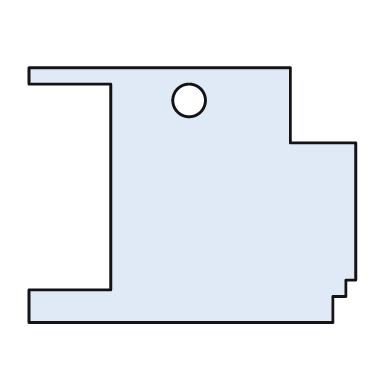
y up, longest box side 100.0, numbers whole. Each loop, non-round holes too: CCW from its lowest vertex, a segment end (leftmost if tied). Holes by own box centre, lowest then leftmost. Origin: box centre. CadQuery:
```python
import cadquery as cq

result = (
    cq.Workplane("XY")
    .moveTo(-50.0, -39.0)
    .lineTo(43.0, -39.0)
    .lineTo(43.0, -31.0)
    .lineTo(47.0, -31.0)
    .lineTo(47.0, -26.0)
    .lineTo(50.0, -26.0)
    .lineTo(50.0, 16.0)
    .lineTo(30.0, 16.0)
    .lineTo(30.0, 39.0)
    .lineTo(-50.0, 39.0)
    .lineTo(-50.0, 34.0)
    .lineTo(-25.0, 34.0)
    .lineTo(-25.0, -29.0)
    .lineTo(-50.0, -29.0)
    .close()
    .moveTo(-1.0, 29.0)
    .circle(5.0)
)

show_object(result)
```